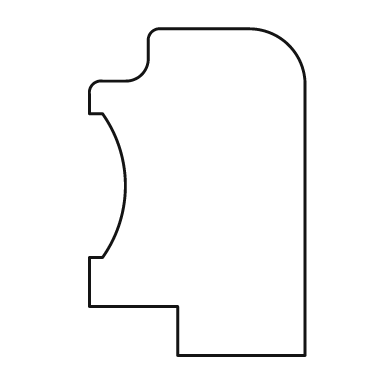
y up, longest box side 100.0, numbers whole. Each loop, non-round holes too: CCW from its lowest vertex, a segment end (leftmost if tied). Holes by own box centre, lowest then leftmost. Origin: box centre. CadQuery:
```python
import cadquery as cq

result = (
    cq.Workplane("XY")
    .moveTo(-6.0, -50.0)
    .lineTo(33.0, -50.0)
    .lineTo(33.0, 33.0)
    .threePointArc((28.0, 45.0), (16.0, 50.0))
    .lineTo(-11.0, 50.0)
    .threePointArc((-14.0, 49.0), (-15.0, 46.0))
    .lineTo(-15.0, 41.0)
    .threePointArc((-17.0, 36.0), (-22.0, 34.0))
    .lineTo(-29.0, 34.0)
    .threePointArc((-32.0, 33.0), (-33.0, 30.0))
    .lineTo(-33.0, 24.0)
    .lineTo(-29.0, 24.0)
    .threePointArc((-22.0, 2.0), (-29.0, -20.0))
    .lineTo(-33.0, -20.0)
    .lineTo(-33.0, -35.0)
    .lineTo(-6.0, -35.0)
    .close()
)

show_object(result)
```